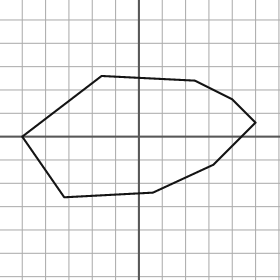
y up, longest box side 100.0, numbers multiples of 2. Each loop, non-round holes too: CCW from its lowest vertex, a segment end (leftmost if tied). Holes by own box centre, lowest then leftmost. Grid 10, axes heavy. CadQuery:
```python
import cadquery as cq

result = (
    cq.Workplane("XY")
    .moveTo(-32.0, -26.0)
    .lineTo(6.0, -24.0)
    .lineTo(32.0, -12.0)
    .lineTo(50.0, 6.0)
    .lineTo(40.0, 16.0)
    .lineTo(24.0, 24.0)
    .lineTo(-16.0, 26.0)
    .lineTo(-50.0, 0.0)
    .close()
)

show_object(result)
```